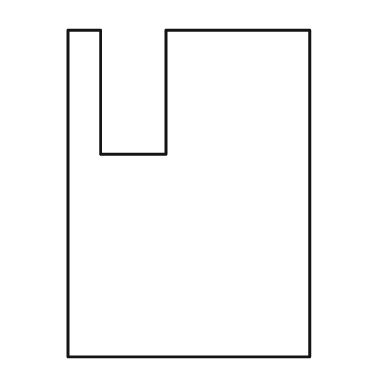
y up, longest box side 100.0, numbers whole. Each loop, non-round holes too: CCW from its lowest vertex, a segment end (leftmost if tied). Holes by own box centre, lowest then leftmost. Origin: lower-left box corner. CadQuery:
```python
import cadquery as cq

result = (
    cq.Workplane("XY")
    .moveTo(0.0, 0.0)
    .lineTo(74.0, 0.0)
    .lineTo(74.0, 100.0)
    .lineTo(30.0, 100.0)
    .lineTo(30.0, 62.0)
    .lineTo(10.0, 62.0)
    .lineTo(10.0, 100.0)
    .lineTo(0.0, 100.0)
    .close()
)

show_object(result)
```